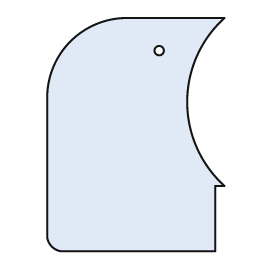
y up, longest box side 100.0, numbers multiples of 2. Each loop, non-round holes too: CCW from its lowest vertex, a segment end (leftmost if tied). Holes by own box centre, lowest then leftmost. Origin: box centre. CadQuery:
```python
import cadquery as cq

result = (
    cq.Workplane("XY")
    .moveTo(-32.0, -50.0)
    .lineTo(34.0, -50.0)
    .lineTo(34.0, -22.0)
    .lineTo(38.0, -22.0)
    .threePointArc((22.0, 14.0), (38.0, 50.0))
    .lineTo(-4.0, 50.0)
    .threePointArc((-28.0, 40.0), (-38.0, 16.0))
    .lineTo(-38.0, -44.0)
    .threePointArc((-36.0, -48.0), (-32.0, -50.0))
    .close()
    .moveTo(10.0, 36.0)
    .circle(2.0)
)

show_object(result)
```